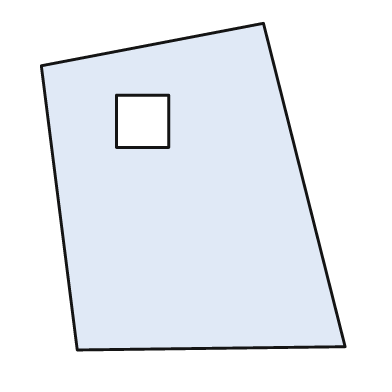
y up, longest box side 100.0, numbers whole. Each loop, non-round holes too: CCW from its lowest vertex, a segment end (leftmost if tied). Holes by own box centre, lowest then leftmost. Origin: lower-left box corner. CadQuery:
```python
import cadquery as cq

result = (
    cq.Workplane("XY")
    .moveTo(11.0, 0.0)
    .lineTo(93.0, 1.0)
    .lineTo(68.0, 100.0)
    .lineTo(0.0, 87.0)
    .close()
    .moveTo(23.0, 62.0)
    .lineTo(39.0, 62.0)
    .lineTo(39.0, 78.0)
    .lineTo(23.0, 78.0)
    .close()
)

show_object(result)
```